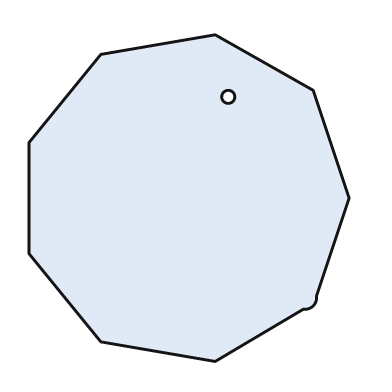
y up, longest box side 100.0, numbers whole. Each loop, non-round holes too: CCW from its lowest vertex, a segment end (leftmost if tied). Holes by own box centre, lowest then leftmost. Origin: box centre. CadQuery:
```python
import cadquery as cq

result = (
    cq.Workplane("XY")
    .moveTo(8.0, -50.0)
    .lineTo(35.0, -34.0)
    .threePointArc((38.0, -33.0), (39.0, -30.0))
    .lineTo(49.0, 0.0)
    .lineTo(38.0, 33.0)
    .lineTo(8.0, 50.0)
    .lineTo(-27.0, 44.0)
    .lineTo(-49.0, 17.0)
    .lineTo(-49.0, -17.0)
    .lineTo(-27.0, -44.0)
    .close()
    .moveTo(12.0, 31.0)
    .circle(2.0)
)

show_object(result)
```